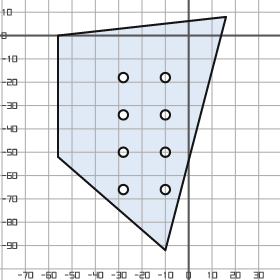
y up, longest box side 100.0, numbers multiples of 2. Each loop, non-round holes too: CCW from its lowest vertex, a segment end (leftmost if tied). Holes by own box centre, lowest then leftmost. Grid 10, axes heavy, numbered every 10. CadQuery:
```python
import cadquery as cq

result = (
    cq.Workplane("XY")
    .moveTo(-10.0, -92.0)
    .lineTo(16.0, 8.0)
    .lineTo(-56.0, 0.0)
    .lineTo(-56.0, -52.0)
    .close()
    .moveTo(-28.0, -66.0)
    .circle(2.0)
    .moveTo(-10.0, -66.0)
    .circle(2.0)
    .moveTo(-28.0, -50.0)
    .circle(2.0)
    .moveTo(-10.0, -50.0)
    .circle(2.0)
    .moveTo(-28.0, -34.0)
    .circle(2.0)
    .moveTo(-10.0, -34.0)
    .circle(2.0)
    .moveTo(-28.0, -18.0)
    .circle(2.0)
    .moveTo(-10.0, -18.0)
    .circle(2.0)
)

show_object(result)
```